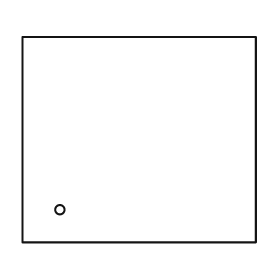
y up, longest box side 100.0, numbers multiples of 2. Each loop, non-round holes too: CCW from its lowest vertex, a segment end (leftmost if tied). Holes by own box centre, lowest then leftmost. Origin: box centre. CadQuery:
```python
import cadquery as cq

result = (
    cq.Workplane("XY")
    .moveTo(-50.0, -44.0)
    .lineTo(50.0, -44.0)
    .lineTo(50.0, 44.0)
    .lineTo(-50.0, 44.0)
    .close()
    .moveTo(-34.0, -30.0)
    .circle(2.0)
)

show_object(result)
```